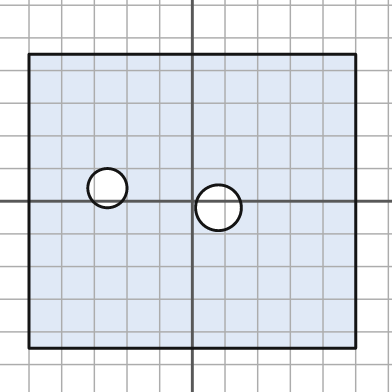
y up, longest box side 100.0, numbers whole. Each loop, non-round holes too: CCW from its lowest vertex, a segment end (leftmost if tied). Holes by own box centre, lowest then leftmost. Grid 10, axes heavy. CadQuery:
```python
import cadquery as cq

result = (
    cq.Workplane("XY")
    .moveTo(-50.0, -45.0)
    .lineTo(50.0, -45.0)
    .lineTo(50.0, 45.0)
    .lineTo(-50.0, 45.0)
    .close()
    .moveTo(8.0, -2.0)
    .circle(7.0)
    .moveTo(-26.0, 4.0)
    .circle(6.0)
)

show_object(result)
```